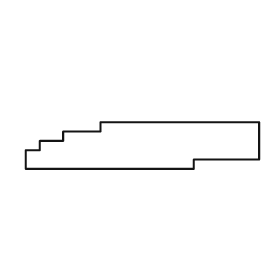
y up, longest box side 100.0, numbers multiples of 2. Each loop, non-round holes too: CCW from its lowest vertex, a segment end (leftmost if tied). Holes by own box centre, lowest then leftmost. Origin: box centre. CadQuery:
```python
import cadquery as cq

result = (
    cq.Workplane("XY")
    .moveTo(-50.0, -10.0)
    .lineTo(22.0, -10.0)
    .lineTo(22.0, -6.0)
    .lineTo(50.0, -6.0)
    .lineTo(50.0, 10.0)
    .lineTo(-18.0, 10.0)
    .lineTo(-18.0, 6.0)
    .lineTo(-34.0, 6.0)
    .lineTo(-34.0, 2.0)
    .lineTo(-44.0, 2.0)
    .lineTo(-44.0, -2.0)
    .lineTo(-50.0, -2.0)
    .close()
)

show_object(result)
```